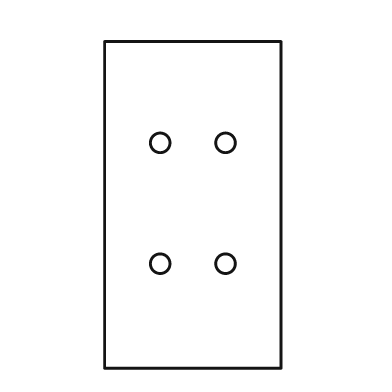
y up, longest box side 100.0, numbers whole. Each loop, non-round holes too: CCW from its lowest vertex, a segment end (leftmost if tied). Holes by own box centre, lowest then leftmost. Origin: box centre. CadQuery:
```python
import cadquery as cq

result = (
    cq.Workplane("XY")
    .moveTo(-27.0, -50.0)
    .lineTo(27.0, -50.0)
    .lineTo(27.0, 50.0)
    .lineTo(-27.0, 50.0)
    .close()
    .moveTo(-10.0, -18.0)
    .circle(3.0)
    .moveTo(10.0, -18.0)
    .circle(3.0)
    .moveTo(-10.0, 19.0)
    .circle(3.0)
    .moveTo(10.0, 19.0)
    .circle(3.0)
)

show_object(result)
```